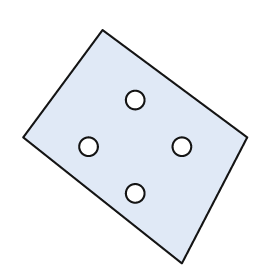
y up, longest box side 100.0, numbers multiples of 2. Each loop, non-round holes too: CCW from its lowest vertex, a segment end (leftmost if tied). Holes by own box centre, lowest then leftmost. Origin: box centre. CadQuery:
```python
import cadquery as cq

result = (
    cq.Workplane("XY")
    .moveTo(20.0, -50.0)
    .lineTo(48.0, 4.0)
    .lineTo(-14.0, 50.0)
    .lineTo(-48.0, 4.0)
    .close()
    .moveTo(0.0, -20.0)
    .circle(4.0)
    .moveTo(-20.0, 0.0)
    .circle(4.0)
    .moveTo(20.0, 0.0)
    .circle(4.0)
    .moveTo(0.0, 20.0)
    .circle(4.0)
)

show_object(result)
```